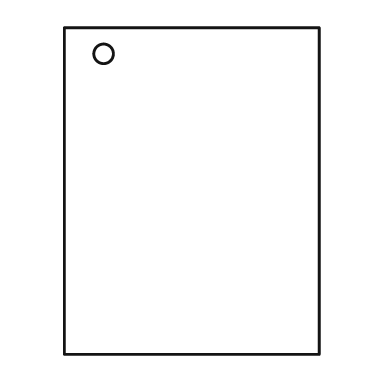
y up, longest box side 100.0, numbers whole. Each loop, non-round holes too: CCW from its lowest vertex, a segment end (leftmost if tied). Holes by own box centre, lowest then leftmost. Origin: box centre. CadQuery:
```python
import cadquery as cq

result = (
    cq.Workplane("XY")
    .moveTo(-39.0, -50.0)
    .lineTo(39.0, -50.0)
    .lineTo(39.0, 50.0)
    .lineTo(-39.0, 50.0)
    .close()
    .moveTo(-27.0, 42.0)
    .circle(3.0)
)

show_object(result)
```